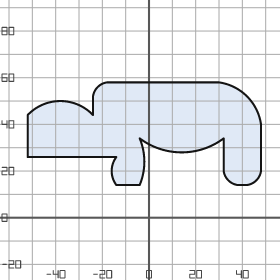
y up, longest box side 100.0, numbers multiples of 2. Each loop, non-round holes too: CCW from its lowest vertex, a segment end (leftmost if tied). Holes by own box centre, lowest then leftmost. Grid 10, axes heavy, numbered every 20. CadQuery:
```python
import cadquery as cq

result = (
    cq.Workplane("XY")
    .moveTo(-14.0, 14.0)
    .lineTo(-4.0, 14.0)
    .threePointArc((-2.0, 24.0), (-4.0, 34.0))
    .threePointArc((14.0, 28.0), (32.0, 34.0))
    .lineTo(32.0, 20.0)
    .threePointArc((34.0, 16.0), (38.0, 14.0))
    .lineTo(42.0, 14.0)
    .threePointArc((46.0, 16.0), (48.0, 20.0))
    .lineTo(48.0, 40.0)
    .threePointArc((42.0, 52.0), (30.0, 58.0))
    .lineTo(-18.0, 58.0)
    .threePointArc((-22.0, 56.0), (-24.0, 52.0))
    .lineTo(-24.0, 44.0)
    .threePointArc((-38.0, 50.0), (-52.0, 44.0))
    .lineTo(-52.0, 26.0)
    .lineTo(-14.0, 26.0)
    .threePointArc((-16.0, 20.0), (-14.0, 14.0))
    .close()
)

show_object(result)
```